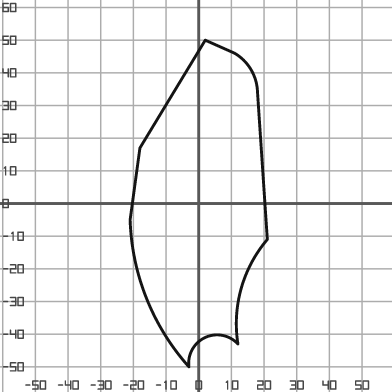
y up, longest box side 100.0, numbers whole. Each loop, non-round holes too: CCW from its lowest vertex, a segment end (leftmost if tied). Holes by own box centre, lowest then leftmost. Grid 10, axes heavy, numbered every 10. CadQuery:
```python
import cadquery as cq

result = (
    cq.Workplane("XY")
    .moveTo(-3.0, -50.0)
    .threePointArc((2.0, -41.0), (12.0, -43.0))
    .threePointArc((13.0, -26.0), (21.0, -11.0))
    .lineTo(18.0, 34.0)
    .threePointArc((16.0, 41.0), (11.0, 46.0))
    .lineTo(2.0, 50.0)
    .lineTo(-18.0, 17.0)
    .lineTo(-21.0, -5.0)
    .threePointArc((-16.0, -29.0), (-3.0, -50.0))
    .close()
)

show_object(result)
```